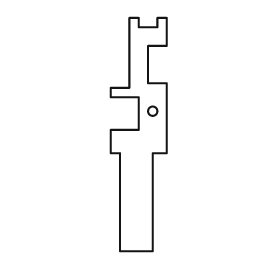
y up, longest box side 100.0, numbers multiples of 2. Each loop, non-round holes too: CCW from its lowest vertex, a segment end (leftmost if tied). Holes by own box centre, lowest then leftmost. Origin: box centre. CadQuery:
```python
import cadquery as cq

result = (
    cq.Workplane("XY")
    .moveTo(-8.0, -50.0)
    .lineTo(6.0, -50.0)
    .lineTo(6.0, -8.0)
    .lineTo(12.0, -8.0)
    .lineTo(12.0, 22.0)
    .lineTo(4.0, 22.0)
    .lineTo(4.0, 38.0)
    .lineTo(12.0, 38.0)
    .lineTo(12.0, 50.0)
    .lineTo(8.0, 50.0)
    .lineTo(8.0, 46.0)
    .lineTo(0.0, 46.0)
    .lineTo(0.0, 50.0)
    .lineTo(-4.0, 50.0)
    .lineTo(-4.0, 20.0)
    .lineTo(-12.0, 20.0)
    .lineTo(-12.0, 16.0)
    .lineTo(0.0, 16.0)
    .lineTo(0.0, 2.0)
    .lineTo(-12.0, 2.0)
    .lineTo(-12.0, -8.0)
    .lineTo(-8.0, -8.0)
    .close()
    .moveTo(6.0, 10.0)
    .circle(2.0)
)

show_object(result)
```